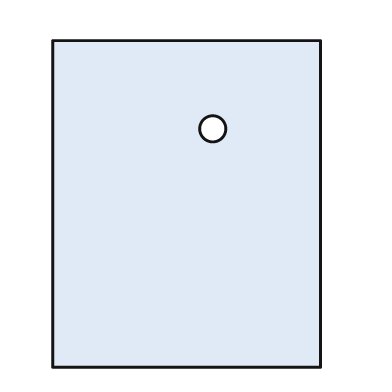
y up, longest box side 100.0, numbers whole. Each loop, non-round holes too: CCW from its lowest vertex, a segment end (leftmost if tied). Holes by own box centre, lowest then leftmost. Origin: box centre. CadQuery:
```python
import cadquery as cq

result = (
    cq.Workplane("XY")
    .moveTo(-41.0, -50.0)
    .lineTo(41.0, -50.0)
    .lineTo(41.0, 50.0)
    .lineTo(-41.0, 50.0)
    .close()
    .moveTo(8.0, 23.0)
    .circle(4.0)
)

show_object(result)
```